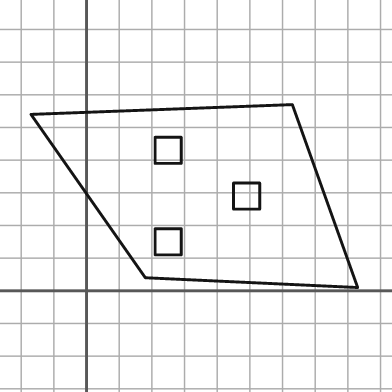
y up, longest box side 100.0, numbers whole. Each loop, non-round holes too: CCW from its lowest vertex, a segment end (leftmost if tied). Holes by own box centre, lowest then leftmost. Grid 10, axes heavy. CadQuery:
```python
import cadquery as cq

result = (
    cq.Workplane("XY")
    .moveTo(83.0, 1.0)
    .lineTo(63.0, 57.0)
    .lineTo(-17.0, 54.0)
    .lineTo(18.0, 4.0)
    .close()
    .moveTo(21.0, 11.0)
    .lineTo(29.0, 11.0)
    .lineTo(29.0, 19.0)
    .lineTo(21.0, 19.0)
    .close()
    .moveTo(45.0, 25.0)
    .lineTo(53.0, 25.0)
    .lineTo(53.0, 33.0)
    .lineTo(45.0, 33.0)
    .close()
    .moveTo(21.0, 39.0)
    .lineTo(29.0, 39.0)
    .lineTo(29.0, 47.0)
    .lineTo(21.0, 47.0)
    .close()
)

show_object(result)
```